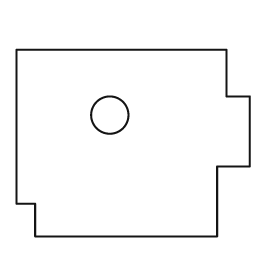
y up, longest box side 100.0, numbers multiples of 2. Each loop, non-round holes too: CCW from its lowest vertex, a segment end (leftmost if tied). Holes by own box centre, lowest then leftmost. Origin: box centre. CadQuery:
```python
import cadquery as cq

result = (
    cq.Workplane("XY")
    .moveTo(-42.0, -40.0)
    .lineTo(36.0, -40.0)
    .lineTo(36.0, -10.0)
    .lineTo(50.0, -10.0)
    .lineTo(50.0, 20.0)
    .lineTo(40.0, 20.0)
    .lineTo(40.0, 40.0)
    .lineTo(-50.0, 40.0)
    .lineTo(-50.0, -26.0)
    .lineTo(-42.0, -26.0)
    .close()
    .moveTo(-10.0, 12.0)
    .circle(8.0)
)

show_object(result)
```